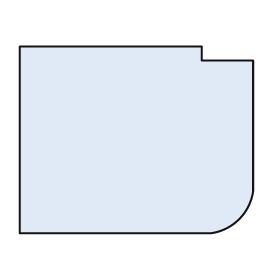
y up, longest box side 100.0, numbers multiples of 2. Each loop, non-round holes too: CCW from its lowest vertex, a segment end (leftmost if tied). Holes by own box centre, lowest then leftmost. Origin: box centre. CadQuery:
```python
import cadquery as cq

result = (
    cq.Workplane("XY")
    .moveTo(-50.0, -40.0)
    .lineTo(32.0, -40.0)
    .threePointArc((44.0, -34.0), (50.0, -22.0))
    .lineTo(50.0, 34.0)
    .lineTo(28.0, 34.0)
    .lineTo(28.0, 40.0)
    .lineTo(-50.0, 40.0)
    .close()
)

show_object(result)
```